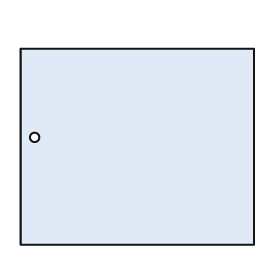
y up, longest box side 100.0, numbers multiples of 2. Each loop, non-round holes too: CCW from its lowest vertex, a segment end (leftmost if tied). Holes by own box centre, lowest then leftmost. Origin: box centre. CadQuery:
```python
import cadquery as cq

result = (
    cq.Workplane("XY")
    .moveTo(-50.0, -42.0)
    .lineTo(50.0, -42.0)
    .lineTo(50.0, 42.0)
    .lineTo(-50.0, 42.0)
    .close()
    .moveTo(-44.0, 4.0)
    .circle(2.0)
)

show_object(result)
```